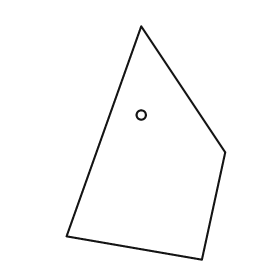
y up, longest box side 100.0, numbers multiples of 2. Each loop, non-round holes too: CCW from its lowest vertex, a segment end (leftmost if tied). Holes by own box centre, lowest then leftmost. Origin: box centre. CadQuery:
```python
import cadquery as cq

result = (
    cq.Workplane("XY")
    .moveTo(24.0, -50.0)
    .lineTo(34.0, -4.0)
    .lineTo(-2.0, 50.0)
    .lineTo(-34.0, -40.0)
    .close()
    .moveTo(-2.0, 12.0)
    .circle(2.0)
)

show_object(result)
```